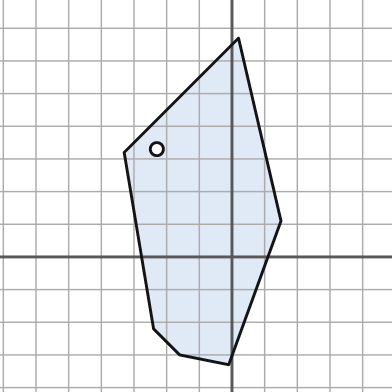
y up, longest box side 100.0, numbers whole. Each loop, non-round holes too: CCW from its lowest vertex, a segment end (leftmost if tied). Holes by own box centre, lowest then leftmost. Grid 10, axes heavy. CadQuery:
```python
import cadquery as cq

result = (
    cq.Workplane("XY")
    .moveTo(-1.0, -33.0)
    .lineTo(15.0, 11.0)
    .lineTo(2.0, 67.0)
    .lineTo(-33.0, 32.0)
    .lineTo(-24.0, -22.0)
    .lineTo(-16.0, -30.0)
    .close()
    .moveTo(-23.0, 33.0)
    .circle(2.0)
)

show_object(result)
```